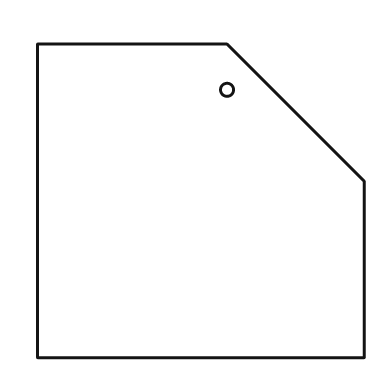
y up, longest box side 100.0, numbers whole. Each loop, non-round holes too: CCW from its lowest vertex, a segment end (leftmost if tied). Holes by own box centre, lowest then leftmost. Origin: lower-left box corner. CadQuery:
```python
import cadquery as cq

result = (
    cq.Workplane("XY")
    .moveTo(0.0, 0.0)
    .lineTo(100.0, 0.0)
    .lineTo(100.0, 54.0)
    .lineTo(58.0, 96.0)
    .lineTo(0.0, 96.0)
    .close()
    .moveTo(58.0, 82.0)
    .circle(2.0)
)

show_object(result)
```